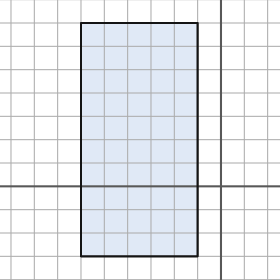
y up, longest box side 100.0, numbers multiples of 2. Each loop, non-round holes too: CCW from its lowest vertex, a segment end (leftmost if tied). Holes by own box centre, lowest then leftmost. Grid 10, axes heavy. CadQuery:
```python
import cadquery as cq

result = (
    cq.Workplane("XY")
    .moveTo(-60.0, -30.0)
    .lineTo(-10.0, -30.0)
    .lineTo(-10.0, 70.0)
    .lineTo(-60.0, 70.0)
    .close()
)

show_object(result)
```